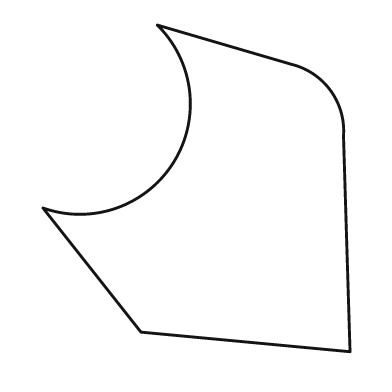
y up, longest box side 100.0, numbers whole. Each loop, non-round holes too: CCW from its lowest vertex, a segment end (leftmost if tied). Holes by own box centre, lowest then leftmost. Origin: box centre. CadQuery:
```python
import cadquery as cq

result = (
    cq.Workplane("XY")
    .moveTo(47.0, -50.0)
    .lineTo(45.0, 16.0)
    .threePointArc((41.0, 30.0), (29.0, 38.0))
    .lineTo(-12.0, 50.0)
    .threePointArc((-7.0, 8.0), (-47.0, -6.0))
    .lineTo(-17.0, -44.0)
    .close()
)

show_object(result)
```